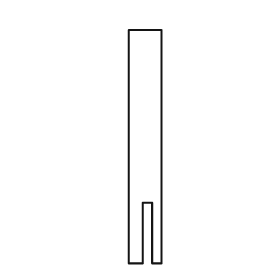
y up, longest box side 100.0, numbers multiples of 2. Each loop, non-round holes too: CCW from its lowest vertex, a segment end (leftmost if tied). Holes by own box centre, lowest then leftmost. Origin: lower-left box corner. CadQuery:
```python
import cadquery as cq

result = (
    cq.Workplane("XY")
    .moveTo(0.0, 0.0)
    .lineTo(6.0, 0.0)
    .lineTo(6.0, 26.0)
    .lineTo(10.0, 26.0)
    .lineTo(10.0, 0.0)
    .lineTo(14.0, 0.0)
    .lineTo(14.0, 100.0)
    .lineTo(0.0, 100.0)
    .close()
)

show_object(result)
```